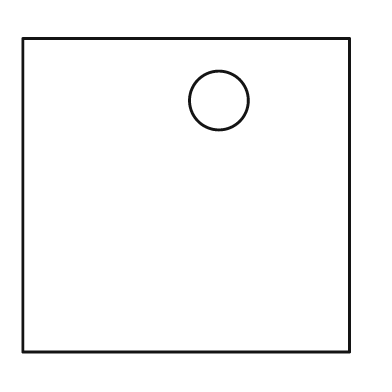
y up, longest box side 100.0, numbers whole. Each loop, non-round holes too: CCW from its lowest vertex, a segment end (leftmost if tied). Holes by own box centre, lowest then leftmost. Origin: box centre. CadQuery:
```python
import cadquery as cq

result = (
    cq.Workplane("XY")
    .moveTo(-50.0, -48.0)
    .lineTo(50.0, -48.0)
    .lineTo(50.0, 48.0)
    .lineTo(-50.0, 48.0)
    .close()
    .moveTo(10.0, 29.0)
    .circle(9.0)
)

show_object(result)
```